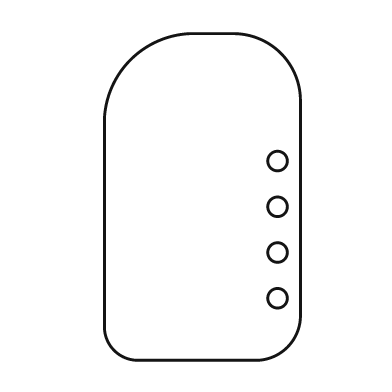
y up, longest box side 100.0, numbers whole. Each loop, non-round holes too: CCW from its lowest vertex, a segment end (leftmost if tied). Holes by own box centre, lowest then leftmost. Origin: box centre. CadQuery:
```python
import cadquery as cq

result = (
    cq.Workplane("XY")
    .moveTo(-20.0, -50.0)
    .lineTo(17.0, -50.0)
    .threePointArc((26.0, -46.0), (30.0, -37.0))
    .lineTo(30.0, 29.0)
    .threePointArc((24.0, 44.0), (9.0, 50.0))
    .lineTo(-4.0, 50.0)
    .threePointArc((-22.0, 42.0), (-30.0, 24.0))
    .lineTo(-30.0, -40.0)
    .threePointArc((-27.0, -47.0), (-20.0, -50.0))
    .close()
    .moveTo(23.0, -31.0)
    .circle(3.0)
    .moveTo(23.0, -17.0)
    .circle(3.0)
    .moveTo(23.0, -3.0)
    .circle(3.0)
    .moveTo(23.0, 11.0)
    .circle(3.0)
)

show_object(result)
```